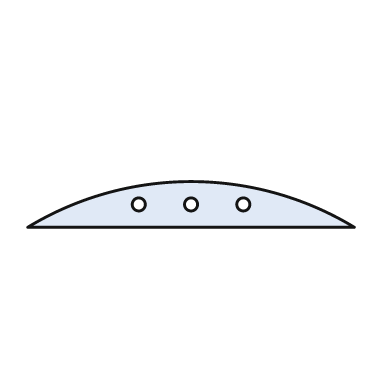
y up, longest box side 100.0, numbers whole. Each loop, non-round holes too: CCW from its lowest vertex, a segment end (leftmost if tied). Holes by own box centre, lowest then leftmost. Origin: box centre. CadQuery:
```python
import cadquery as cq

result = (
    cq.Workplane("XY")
    .moveTo(-50.0, -7.0)
    .lineTo(50.0, -7.0)
    .threePointArc((0.0, 7.0), (-50.0, -7.0))
    .close()
    .moveTo(-16.0, 0.0)
    .circle(2.0)
    .moveTo(0.0, 0.0)
    .circle(2.0)
    .moveTo(16.0, 0.0)
    .circle(2.0)
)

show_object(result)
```